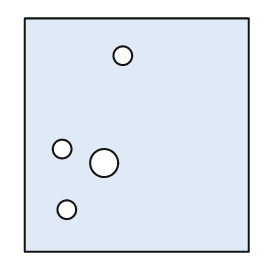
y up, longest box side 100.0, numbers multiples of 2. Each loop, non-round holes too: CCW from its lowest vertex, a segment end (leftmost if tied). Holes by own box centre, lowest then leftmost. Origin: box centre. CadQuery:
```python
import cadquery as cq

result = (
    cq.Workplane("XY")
    .moveTo(-48.0, -50.0)
    .lineTo(48.0, -50.0)
    .lineTo(48.0, 50.0)
    .lineTo(-48.0, 50.0)
    .close()
    .moveTo(-30.0, -32.0)
    .circle(4.0)
    .moveTo(-14.0, -12.0)
    .circle(6.0)
    .moveTo(-32.0, -6.0)
    .circle(4.0)
    .moveTo(-6.0, 34.0)
    .circle(4.0)
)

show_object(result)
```